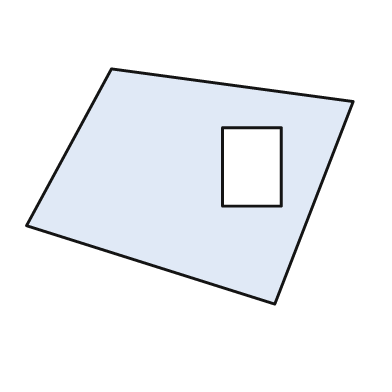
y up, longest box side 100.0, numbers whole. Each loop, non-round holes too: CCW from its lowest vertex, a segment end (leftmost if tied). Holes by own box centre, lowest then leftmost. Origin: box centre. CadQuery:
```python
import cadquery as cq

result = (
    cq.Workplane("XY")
    .moveTo(26.0, -36.0)
    .lineTo(50.0, 26.0)
    .lineTo(-24.0, 36.0)
    .lineTo(-50.0, -12.0)
    .close()
    .moveTo(10.0, -6.0)
    .lineTo(28.0, -6.0)
    .lineTo(28.0, 18.0)
    .lineTo(10.0, 18.0)
    .close()
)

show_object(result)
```